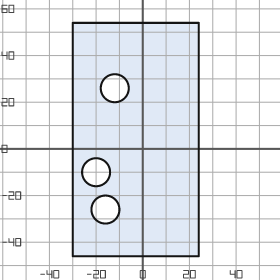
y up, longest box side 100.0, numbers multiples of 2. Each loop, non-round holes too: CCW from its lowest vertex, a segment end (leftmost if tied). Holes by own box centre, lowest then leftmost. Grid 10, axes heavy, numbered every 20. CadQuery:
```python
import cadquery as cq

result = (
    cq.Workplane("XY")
    .moveTo(-30.0, -46.0)
    .lineTo(24.0, -46.0)
    .lineTo(24.0, 54.0)
    .lineTo(-30.0, 54.0)
    .close()
    .moveTo(-16.0, -26.0)
    .circle(6.0)
    .moveTo(-20.0, -10.0)
    .circle(6.0)
    .moveTo(-12.0, 26.0)
    .circle(6.0)
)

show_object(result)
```